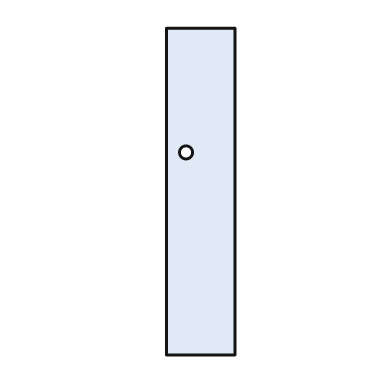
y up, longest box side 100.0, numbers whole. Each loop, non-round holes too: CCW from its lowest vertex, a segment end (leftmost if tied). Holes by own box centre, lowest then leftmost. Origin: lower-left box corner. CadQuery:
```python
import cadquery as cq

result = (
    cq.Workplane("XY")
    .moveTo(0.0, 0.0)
    .lineTo(21.0, 0.0)
    .lineTo(21.0, 100.0)
    .lineTo(0.0, 100.0)
    .close()
    .moveTo(6.0, 62.0)
    .circle(2.0)
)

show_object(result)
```